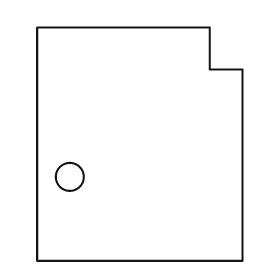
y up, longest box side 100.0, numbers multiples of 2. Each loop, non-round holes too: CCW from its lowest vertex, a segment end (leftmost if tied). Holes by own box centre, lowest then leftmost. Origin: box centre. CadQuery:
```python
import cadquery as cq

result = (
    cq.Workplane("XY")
    .moveTo(-44.0, -50.0)
    .lineTo(44.0, -50.0)
    .lineTo(44.0, 32.0)
    .lineTo(30.0, 32.0)
    .lineTo(30.0, 50.0)
    .lineTo(-44.0, 50.0)
    .close()
    .moveTo(-30.0, -14.0)
    .circle(6.0)
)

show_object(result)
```